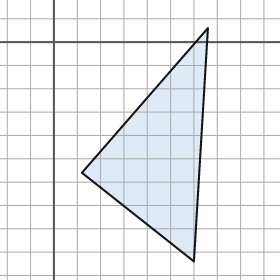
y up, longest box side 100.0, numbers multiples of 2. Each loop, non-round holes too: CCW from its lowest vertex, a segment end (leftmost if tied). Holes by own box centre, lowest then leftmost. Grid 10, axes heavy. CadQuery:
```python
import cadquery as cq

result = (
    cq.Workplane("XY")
    .moveTo(60.0, -94.0)
    .lineTo(66.0, 6.0)
    .lineTo(12.0, -56.0)
    .close()
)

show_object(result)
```